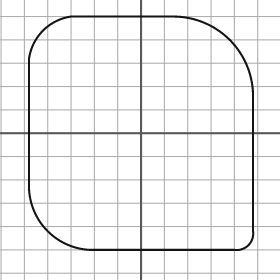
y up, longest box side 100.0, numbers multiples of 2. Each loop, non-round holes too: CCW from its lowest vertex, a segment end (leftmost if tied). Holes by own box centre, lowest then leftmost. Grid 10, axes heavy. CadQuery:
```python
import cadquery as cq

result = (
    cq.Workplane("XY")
    .moveTo(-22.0, -50.0)
    .lineTo(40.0, -50.0)
    .threePointArc((46.0, -48.0), (48.0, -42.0))
    .lineTo(48.0, 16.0)
    .threePointArc((38.0, 40.0), (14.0, 50.0))
    .lineTo(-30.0, 50.0)
    .threePointArc((-42.0, 44.0), (-48.0, 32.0))
    .lineTo(-48.0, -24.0)
    .threePointArc((-40.0, -42.0), (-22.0, -50.0))
    .close()
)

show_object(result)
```